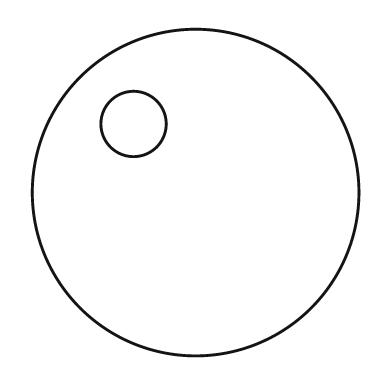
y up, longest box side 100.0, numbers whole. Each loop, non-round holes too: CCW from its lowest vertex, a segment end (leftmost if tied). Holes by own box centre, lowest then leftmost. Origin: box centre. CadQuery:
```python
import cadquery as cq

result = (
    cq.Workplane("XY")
    .moveTo(0.0, 0.0)
    .circle(50.0)
    .moveTo(-19.0, 21.0)
    .circle(10.0)
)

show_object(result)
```